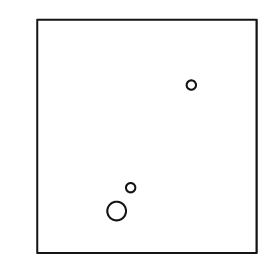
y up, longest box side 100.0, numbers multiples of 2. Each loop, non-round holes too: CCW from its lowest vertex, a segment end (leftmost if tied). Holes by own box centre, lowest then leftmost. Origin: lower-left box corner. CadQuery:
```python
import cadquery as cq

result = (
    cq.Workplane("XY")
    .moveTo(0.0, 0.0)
    .lineTo(94.0, 0.0)
    .lineTo(94.0, 100.0)
    .lineTo(0.0, 100.0)
    .close()
    .moveTo(34.0, 18.0)
    .circle(4.0)
    .moveTo(40.0, 28.0)
    .circle(2.0)
    .moveTo(66.0, 72.0)
    .circle(2.0)
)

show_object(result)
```